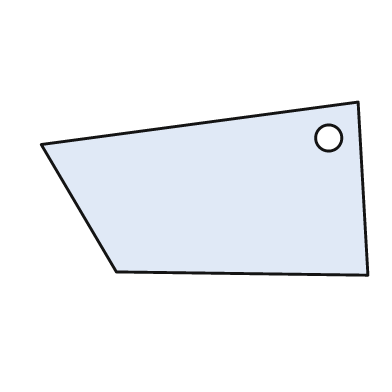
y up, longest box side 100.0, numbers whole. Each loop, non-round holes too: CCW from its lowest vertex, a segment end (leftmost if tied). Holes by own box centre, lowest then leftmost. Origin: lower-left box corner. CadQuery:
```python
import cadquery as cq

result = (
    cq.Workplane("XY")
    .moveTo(100.0, 0.0)
    .lineTo(97.0, 53.0)
    .lineTo(0.0, 40.0)
    .lineTo(23.0, 1.0)
    .close()
    .moveTo(88.0, 42.0)
    .circle(4.0)
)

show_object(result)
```